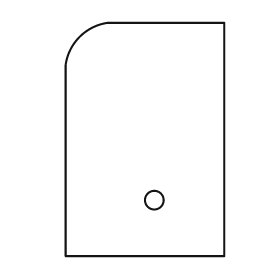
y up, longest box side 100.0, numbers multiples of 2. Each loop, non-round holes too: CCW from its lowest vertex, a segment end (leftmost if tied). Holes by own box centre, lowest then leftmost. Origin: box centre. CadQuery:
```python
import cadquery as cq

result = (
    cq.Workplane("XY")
    .moveTo(-34.0, -50.0)
    .lineTo(34.0, -50.0)
    .lineTo(34.0, 50.0)
    .lineTo(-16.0, 50.0)
    .threePointArc((-28.0, 44.0), (-34.0, 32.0))
    .close()
    .moveTo(4.0, -26.0)
    .circle(4.0)
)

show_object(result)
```